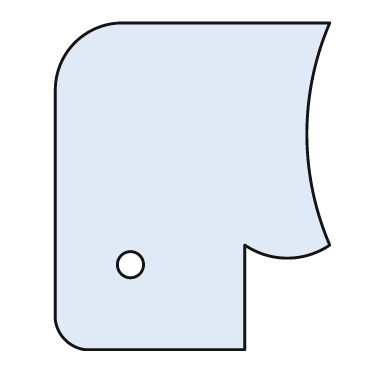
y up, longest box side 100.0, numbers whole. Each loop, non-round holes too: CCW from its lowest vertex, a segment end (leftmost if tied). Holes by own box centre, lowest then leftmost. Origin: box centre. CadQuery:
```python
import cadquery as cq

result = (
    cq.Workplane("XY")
    .moveTo(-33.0, -50.0)
    .lineTo(16.0, -50.0)
    .lineTo(16.0, -18.0)
    .threePointArc((29.0, -22.0), (42.0, -18.0))
    .threePointArc((35.0, 16.0), (42.0, 50.0))
    .lineTo(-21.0, 50.0)
    .threePointArc((-36.0, 44.0), (-42.0, 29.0))
    .lineTo(-42.0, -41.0)
    .threePointArc((-39.0, -47.0), (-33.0, -50.0))
    .close()
    .moveTo(-19.0, -24.0)
    .circle(4.0)
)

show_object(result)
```